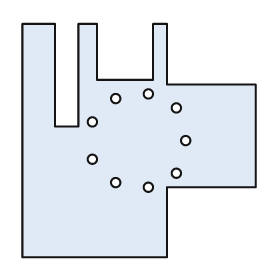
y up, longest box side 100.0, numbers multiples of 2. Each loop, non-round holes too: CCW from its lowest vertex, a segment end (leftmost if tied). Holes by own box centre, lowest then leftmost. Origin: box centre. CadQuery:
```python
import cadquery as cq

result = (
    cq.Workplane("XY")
    .moveTo(-50.0, -50.0)
    .lineTo(12.0, -50.0)
    .lineTo(12.0, -20.0)
    .lineTo(50.0, -20.0)
    .lineTo(50.0, 24.0)
    .lineTo(12.0, 24.0)
    .lineTo(12.0, 50.0)
    .lineTo(6.0, 50.0)
    .lineTo(6.0, 26.0)
    .lineTo(-18.0, 26.0)
    .lineTo(-18.0, 50.0)
    .lineTo(-26.0, 50.0)
    .lineTo(-26.0, 6.0)
    .lineTo(-36.0, 6.0)
    .lineTo(-36.0, 50.0)
    .lineTo(-50.0, 50.0)
    .close()
    .moveTo(4.0, -20.0)
    .circle(2.0)
    .moveTo(-10.0, -18.0)
    .circle(2.0)
    .moveTo(16.0, -14.0)
    .circle(2.0)
    .moveTo(-20.0, -8.0)
    .circle(2.0)
    .moveTo(20.0, 0.0)
    .circle(2.0)
    .moveTo(-20.0, 8.0)
    .circle(2.0)
    .moveTo(16.0, 14.0)
    .circle(2.0)
    .moveTo(-10.0, 18.0)
    .circle(2.0)
    .moveTo(4.0, 20.0)
    .circle(2.0)
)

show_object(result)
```